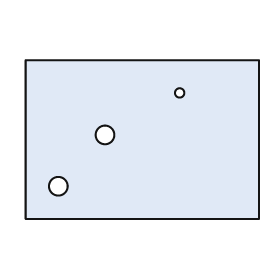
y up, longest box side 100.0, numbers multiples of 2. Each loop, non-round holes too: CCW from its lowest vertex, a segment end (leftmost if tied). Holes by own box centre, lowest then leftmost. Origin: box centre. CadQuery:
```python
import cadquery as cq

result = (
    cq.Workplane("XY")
    .moveTo(-50.0, -34.0)
    .lineTo(50.0, -34.0)
    .lineTo(50.0, 34.0)
    .lineTo(-50.0, 34.0)
    .close()
    .moveTo(-36.0, -20.0)
    .circle(4.0)
    .moveTo(-16.0, 2.0)
    .circle(4.0)
    .moveTo(16.0, 20.0)
    .circle(2.0)
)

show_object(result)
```